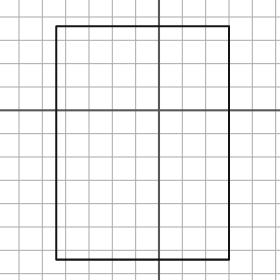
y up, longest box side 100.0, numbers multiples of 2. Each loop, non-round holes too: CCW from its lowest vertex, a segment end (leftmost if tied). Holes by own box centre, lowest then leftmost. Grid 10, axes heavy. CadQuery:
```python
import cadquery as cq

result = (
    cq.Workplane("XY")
    .moveTo(-44.0, -64.0)
    .lineTo(30.0, -64.0)
    .lineTo(30.0, 36.0)
    .lineTo(-44.0, 36.0)
    .close()
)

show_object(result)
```